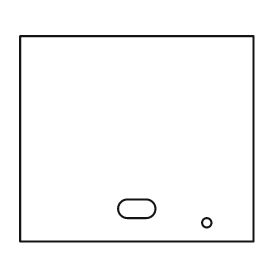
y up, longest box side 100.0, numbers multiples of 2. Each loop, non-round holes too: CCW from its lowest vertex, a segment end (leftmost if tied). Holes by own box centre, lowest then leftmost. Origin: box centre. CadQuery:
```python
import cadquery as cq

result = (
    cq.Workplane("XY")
    .moveTo(-50.0, -44.0)
    .lineTo(50.0, -44.0)
    .lineTo(50.0, 44.0)
    .lineTo(-50.0, 44.0)
    .close()
    .moveTo(30.0, -36.0)
    .circle(2.0)
    .moveTo(-4.0, -34.0)
    .lineTo(4.0, -34.0)
    .threePointArc((8.0, -30.0), (4.0, -26.0))
    .lineTo(-4.0, -26.0)
    .threePointArc((-8.0, -30.0), (-4.0, -34.0))
    .close()
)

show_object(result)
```